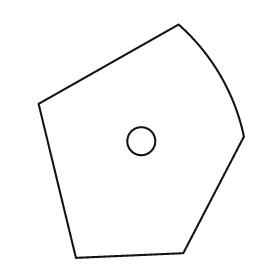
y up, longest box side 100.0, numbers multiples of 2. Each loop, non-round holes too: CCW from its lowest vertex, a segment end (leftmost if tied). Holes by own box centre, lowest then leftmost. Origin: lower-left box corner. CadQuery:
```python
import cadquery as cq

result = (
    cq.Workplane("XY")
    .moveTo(16.0, 0.0)
    .lineTo(62.0, 2.0)
    .lineTo(88.0, 52.0)
    .threePointArc((78.0, 78.0), (60.0, 100.0))
    .lineTo(0.0, 66.0)
    .close()
    .moveTo(44.0, 50.0)
    .circle(6.0)
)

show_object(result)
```